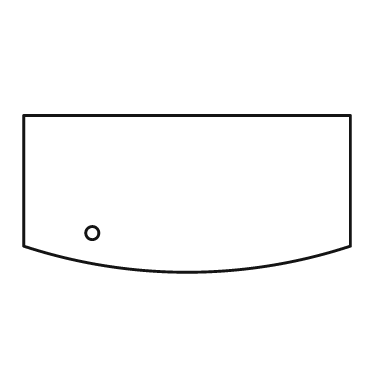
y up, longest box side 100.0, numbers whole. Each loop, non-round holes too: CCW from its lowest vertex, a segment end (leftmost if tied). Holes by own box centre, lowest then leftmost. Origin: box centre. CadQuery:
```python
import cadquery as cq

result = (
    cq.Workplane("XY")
    .moveTo(-50.0, -16.0)
    .threePointArc((0.0, -24.0), (50.0, -16.0))
    .lineTo(50.0, 24.0)
    .lineTo(-50.0, 24.0)
    .close()
    .moveTo(-29.0, -12.0)
    .circle(2.0)
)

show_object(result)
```